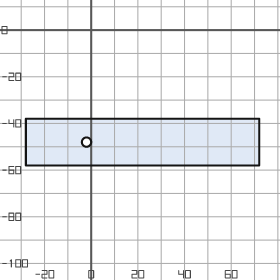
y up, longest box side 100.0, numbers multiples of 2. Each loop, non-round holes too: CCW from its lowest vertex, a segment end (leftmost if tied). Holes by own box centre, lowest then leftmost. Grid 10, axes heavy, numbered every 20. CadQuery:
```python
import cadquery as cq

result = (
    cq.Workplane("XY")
    .moveTo(-28.0, -58.0)
    .lineTo(72.0, -58.0)
    .lineTo(72.0, -38.0)
    .lineTo(-28.0, -38.0)
    .close()
    .moveTo(-2.0, -48.0)
    .circle(2.0)
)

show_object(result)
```